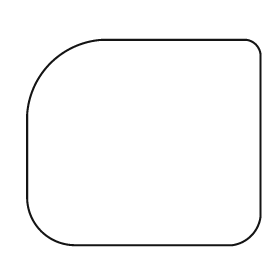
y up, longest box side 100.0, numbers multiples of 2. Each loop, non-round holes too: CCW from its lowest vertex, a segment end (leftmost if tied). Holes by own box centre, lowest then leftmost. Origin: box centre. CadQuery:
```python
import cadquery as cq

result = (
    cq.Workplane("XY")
    .moveTo(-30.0, -44.0)
    .lineTo(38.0, -44.0)
    .threePointArc((46.0, -40.0), (50.0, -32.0))
    .lineTo(50.0, 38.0)
    .threePointArc((48.0, 42.0), (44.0, 44.0))
    .lineTo(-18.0, 44.0)
    .threePointArc((-40.0, 34.0), (-50.0, 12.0))
    .lineTo(-50.0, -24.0)
    .threePointArc((-44.0, -38.0), (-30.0, -44.0))
    .close()
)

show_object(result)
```